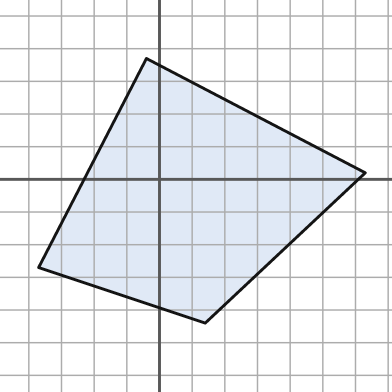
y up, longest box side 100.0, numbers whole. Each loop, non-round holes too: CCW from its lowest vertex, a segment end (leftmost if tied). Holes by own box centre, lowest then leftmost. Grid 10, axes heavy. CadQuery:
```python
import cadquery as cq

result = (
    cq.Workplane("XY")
    .moveTo(14.0, -44.0)
    .lineTo(63.0, 2.0)
    .lineTo(-4.0, 37.0)
    .lineTo(-37.0, -27.0)
    .close()
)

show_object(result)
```